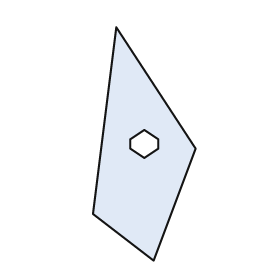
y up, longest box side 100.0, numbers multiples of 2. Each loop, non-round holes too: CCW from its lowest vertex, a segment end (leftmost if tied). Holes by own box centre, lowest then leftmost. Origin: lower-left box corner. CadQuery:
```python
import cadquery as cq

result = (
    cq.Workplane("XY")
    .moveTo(26.0, 0.0)
    .lineTo(44.0, 48.0)
    .lineTo(10.0, 100.0)
    .lineTo(0.0, 20.0)
    .close()
    .moveTo(22.0, 44.0)
    .lineTo(28.0, 48.0)
    .lineTo(28.0, 52.0)
    .lineTo(22.0, 56.0)
    .lineTo(16.0, 52.0)
    .lineTo(16.0, 48.0)
    .close()
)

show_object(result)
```